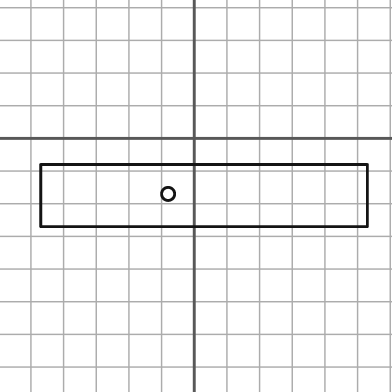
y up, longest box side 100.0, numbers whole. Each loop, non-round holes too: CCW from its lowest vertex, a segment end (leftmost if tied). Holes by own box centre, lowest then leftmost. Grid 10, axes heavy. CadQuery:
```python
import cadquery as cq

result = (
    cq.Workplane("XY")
    .moveTo(-47.0, -27.0)
    .lineTo(53.0, -27.0)
    .lineTo(53.0, -8.0)
    .lineTo(-47.0, -8.0)
    .close()
    .moveTo(-8.0, -17.0)
    .circle(2.0)
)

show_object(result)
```